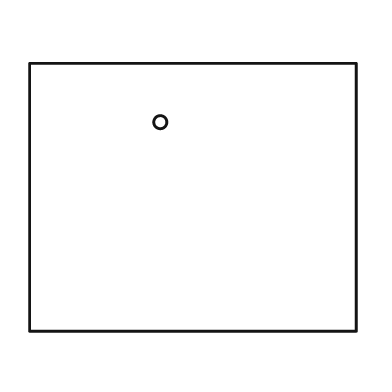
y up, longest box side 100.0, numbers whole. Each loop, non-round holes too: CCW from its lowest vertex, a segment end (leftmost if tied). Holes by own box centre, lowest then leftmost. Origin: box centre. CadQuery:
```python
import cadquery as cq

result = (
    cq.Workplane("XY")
    .moveTo(-50.0, -41.0)
    .lineTo(50.0, -41.0)
    .lineTo(50.0, 41.0)
    .lineTo(-50.0, 41.0)
    .close()
    .moveTo(-10.0, 23.0)
    .circle(2.0)
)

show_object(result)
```